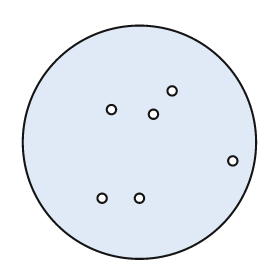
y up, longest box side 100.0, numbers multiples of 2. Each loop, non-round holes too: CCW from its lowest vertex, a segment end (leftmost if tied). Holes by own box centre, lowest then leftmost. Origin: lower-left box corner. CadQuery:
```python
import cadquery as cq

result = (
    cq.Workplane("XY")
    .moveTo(50.0, 50.0)
    .circle(50.0)
    .moveTo(34.0, 26.0)
    .circle(2.0)
    .moveTo(50.0, 26.0)
    .circle(2.0)
    .moveTo(90.0, 42.0)
    .circle(2.0)
    .moveTo(56.0, 62.0)
    .circle(2.0)
    .moveTo(38.0, 64.0)
    .circle(2.0)
    .moveTo(64.0, 72.0)
    .circle(2.0)
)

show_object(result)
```